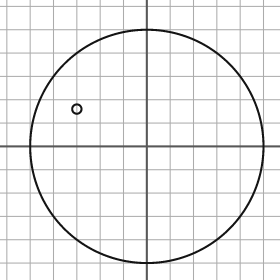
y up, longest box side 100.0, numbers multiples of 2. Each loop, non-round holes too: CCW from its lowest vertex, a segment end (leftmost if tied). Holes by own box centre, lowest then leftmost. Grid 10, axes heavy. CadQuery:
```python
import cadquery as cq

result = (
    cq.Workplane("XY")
    .moveTo(0.0, 0.0)
    .circle(50.0)
    .moveTo(-30.0, 16.0)
    .circle(2.0)
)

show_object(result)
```